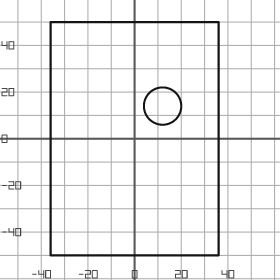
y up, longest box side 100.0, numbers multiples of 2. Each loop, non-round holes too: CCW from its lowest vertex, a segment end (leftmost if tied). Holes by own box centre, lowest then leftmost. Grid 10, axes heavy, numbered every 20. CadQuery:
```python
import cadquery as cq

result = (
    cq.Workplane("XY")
    .moveTo(-36.0, -50.0)
    .lineTo(36.0, -50.0)
    .lineTo(36.0, 50.0)
    .lineTo(-36.0, 50.0)
    .close()
    .moveTo(12.0, 14.0)
    .circle(8.0)
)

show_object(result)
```